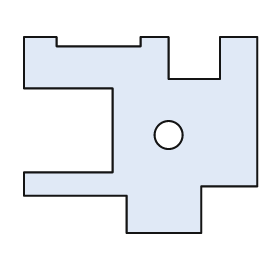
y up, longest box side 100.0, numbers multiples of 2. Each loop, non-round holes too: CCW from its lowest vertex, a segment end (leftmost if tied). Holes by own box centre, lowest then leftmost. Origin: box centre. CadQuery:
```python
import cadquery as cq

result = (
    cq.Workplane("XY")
    .moveTo(-6.0, -42.0)
    .lineTo(26.0, -42.0)
    .lineTo(26.0, -22.0)
    .lineTo(50.0, -22.0)
    .lineTo(50.0, 42.0)
    .lineTo(34.0, 42.0)
    .lineTo(34.0, 24.0)
    .lineTo(12.0, 24.0)
    .lineTo(12.0, 42.0)
    .lineTo(0.0, 42.0)
    .lineTo(0.0, 38.0)
    .lineTo(-36.0, 38.0)
    .lineTo(-36.0, 42.0)
    .lineTo(-50.0, 42.0)
    .lineTo(-50.0, 20.0)
    .lineTo(-12.0, 20.0)
    .lineTo(-12.0, -16.0)
    .lineTo(-50.0, -16.0)
    .lineTo(-50.0, -26.0)
    .lineTo(-6.0, -26.0)
    .close()
    .moveTo(12.0, 0.0)
    .circle(6.0)
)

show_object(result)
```